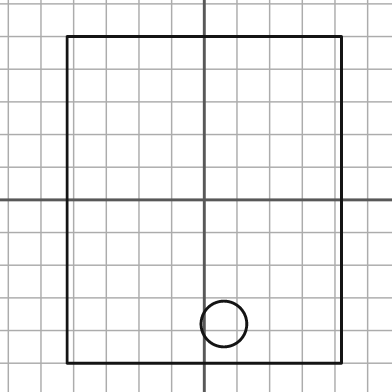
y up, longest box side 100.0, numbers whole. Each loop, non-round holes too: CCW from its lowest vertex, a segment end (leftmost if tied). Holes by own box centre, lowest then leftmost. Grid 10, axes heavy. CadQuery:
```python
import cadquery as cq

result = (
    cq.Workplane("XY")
    .moveTo(-42.0, -50.0)
    .lineTo(42.0, -50.0)
    .lineTo(42.0, 50.0)
    .lineTo(-42.0, 50.0)
    .close()
    .moveTo(6.0, -38.0)
    .circle(7.0)
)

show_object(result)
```